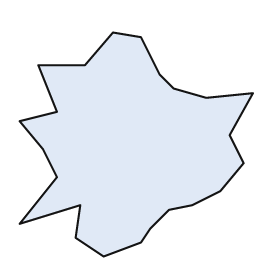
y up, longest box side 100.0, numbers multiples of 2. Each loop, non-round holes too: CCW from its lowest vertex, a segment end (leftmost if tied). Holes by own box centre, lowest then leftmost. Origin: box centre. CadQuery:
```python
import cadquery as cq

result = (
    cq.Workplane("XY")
    .moveTo(-14.0, -48.0)
    .lineTo(2.0, -42.0)
    .lineTo(6.0, -36.0)
    .lineTo(14.0, -28.0)
    .lineTo(24.0, -26.0)
    .lineTo(36.0, -20.0)
    .lineTo(46.0, -8.0)
    .lineTo(40.0, 4.0)
    .lineTo(50.0, 22.0)
    .lineTo(30.0, 20.0)
    .lineTo(16.0, 24.0)
    .lineTo(10.0, 30.0)
    .lineTo(2.0, 46.0)
    .lineTo(-10.0, 48.0)
    .lineTo(-22.0, 34.0)
    .lineTo(-42.0, 34.0)
    .lineTo(-34.0, 14.0)
    .lineTo(-50.0, 10.0)
    .lineTo(-40.0, -2.0)
    .lineTo(-34.0, -14.0)
    .lineTo(-50.0, -34.0)
    .lineTo(-24.0, -26.0)
    .lineTo(-26.0, -40.0)
    .close()
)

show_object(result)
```